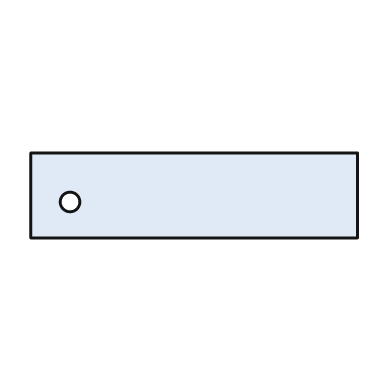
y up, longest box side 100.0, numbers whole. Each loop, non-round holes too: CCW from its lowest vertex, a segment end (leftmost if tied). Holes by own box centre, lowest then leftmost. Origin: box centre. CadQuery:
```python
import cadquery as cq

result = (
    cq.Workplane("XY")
    .moveTo(-50.0, -13.0)
    .lineTo(50.0, -13.0)
    .lineTo(50.0, 13.0)
    .lineTo(-50.0, 13.0)
    .close()
    .moveTo(-38.0, -2.0)
    .circle(3.0)
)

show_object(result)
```